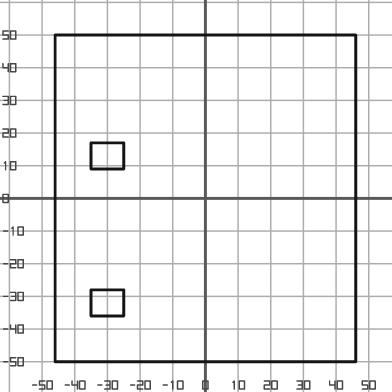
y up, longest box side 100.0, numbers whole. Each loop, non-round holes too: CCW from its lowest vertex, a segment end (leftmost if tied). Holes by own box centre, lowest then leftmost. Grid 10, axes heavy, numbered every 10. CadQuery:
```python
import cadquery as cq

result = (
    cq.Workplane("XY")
    .moveTo(-46.0, -50.0)
    .lineTo(46.0, -50.0)
    .lineTo(46.0, 50.0)
    .lineTo(-46.0, 50.0)
    .close()
    .moveTo(-35.0, -36.0)
    .lineTo(-25.0, -36.0)
    .lineTo(-25.0, -28.0)
    .lineTo(-35.0, -28.0)
    .close()
    .moveTo(-35.0, 9.0)
    .lineTo(-25.0, 9.0)
    .lineTo(-25.0, 17.0)
    .lineTo(-35.0, 17.0)
    .close()
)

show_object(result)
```